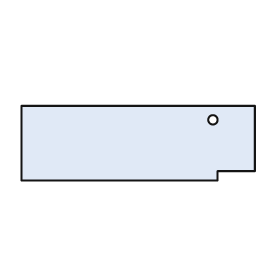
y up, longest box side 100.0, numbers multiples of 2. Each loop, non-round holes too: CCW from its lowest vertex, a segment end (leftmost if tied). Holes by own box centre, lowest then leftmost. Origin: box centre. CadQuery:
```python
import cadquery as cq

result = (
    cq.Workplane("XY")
    .moveTo(-50.0, -16.0)
    .lineTo(34.0, -16.0)
    .lineTo(34.0, -12.0)
    .lineTo(50.0, -12.0)
    .lineTo(50.0, 16.0)
    .lineTo(-50.0, 16.0)
    .close()
    .moveTo(32.0, 10.0)
    .circle(2.0)
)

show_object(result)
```